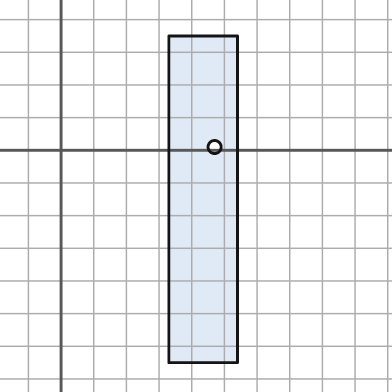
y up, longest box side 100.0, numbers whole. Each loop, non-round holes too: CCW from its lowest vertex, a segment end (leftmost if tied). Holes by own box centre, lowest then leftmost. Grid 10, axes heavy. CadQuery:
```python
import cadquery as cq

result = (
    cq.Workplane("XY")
    .moveTo(33.0, -65.0)
    .lineTo(54.0, -65.0)
    .lineTo(54.0, 35.0)
    .lineTo(33.0, 35.0)
    .close()
    .moveTo(47.0, 1.0)
    .circle(2.0)
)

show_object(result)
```